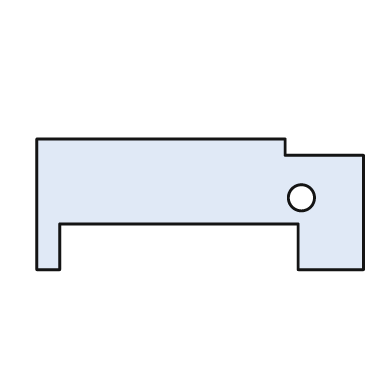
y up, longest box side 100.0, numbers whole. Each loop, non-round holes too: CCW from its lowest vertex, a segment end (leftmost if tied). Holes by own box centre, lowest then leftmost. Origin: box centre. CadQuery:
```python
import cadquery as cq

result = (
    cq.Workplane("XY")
    .moveTo(-50.0, -20.0)
    .lineTo(-43.0, -20.0)
    .lineTo(-43.0, -6.0)
    .lineTo(30.0, -6.0)
    .lineTo(30.0, -20.0)
    .lineTo(50.0, -20.0)
    .lineTo(50.0, 15.0)
    .lineTo(26.0, 15.0)
    .lineTo(26.0, 20.0)
    .lineTo(-50.0, 20.0)
    .close()
    .moveTo(31.0, 2.0)
    .circle(4.0)
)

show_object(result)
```